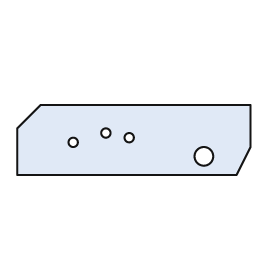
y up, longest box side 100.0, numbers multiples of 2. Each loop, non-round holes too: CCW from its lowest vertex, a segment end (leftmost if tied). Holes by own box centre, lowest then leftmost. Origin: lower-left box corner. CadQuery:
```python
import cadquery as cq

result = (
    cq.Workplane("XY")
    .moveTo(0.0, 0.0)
    .lineTo(94.0, 0.0)
    .lineTo(100.0, 12.0)
    .lineTo(100.0, 30.0)
    .lineTo(10.0, 30.0)
    .lineTo(0.0, 20.0)
    .close()
    .moveTo(80.0, 8.0)
    .circle(4.0)
    .moveTo(24.0, 14.0)
    .circle(2.0)
    .moveTo(48.0, 16.0)
    .circle(2.0)
    .moveTo(38.0, 18.0)
    .circle(2.0)
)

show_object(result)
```